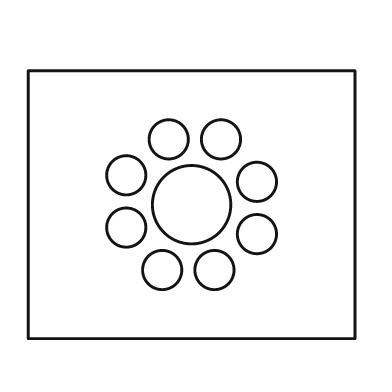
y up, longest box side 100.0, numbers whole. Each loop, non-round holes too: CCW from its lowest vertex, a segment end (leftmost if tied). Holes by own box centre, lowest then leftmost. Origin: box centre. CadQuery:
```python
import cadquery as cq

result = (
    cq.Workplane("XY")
    .moveTo(-50.0, -41.0)
    .lineTo(50.0, -41.0)
    .lineTo(50.0, 41.0)
    .lineTo(-50.0, 41.0)
    .close()
    .moveTo(-9.0, -20.0)
    .circle(6.0)
    .moveTo(7.0, -20.0)
    .circle(6.0)
    .moveTo(20.0, -9.0)
    .circle(6.0)
    .moveTo(-20.0, -7.0)
    .circle(6.0)
    .moveTo(0.0, 0.0)
    .circle(12.0)
    .moveTo(20.0, 7.0)
    .circle(6.0)
    .moveTo(-20.0, 9.0)
    .circle(6.0)
    .moveTo(-7.0, 20.0)
    .circle(6.0)
    .moveTo(9.0, 20.0)
    .circle(6.0)
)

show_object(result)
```